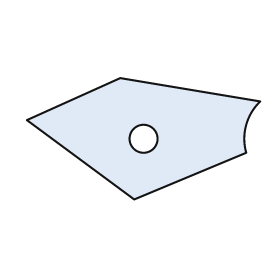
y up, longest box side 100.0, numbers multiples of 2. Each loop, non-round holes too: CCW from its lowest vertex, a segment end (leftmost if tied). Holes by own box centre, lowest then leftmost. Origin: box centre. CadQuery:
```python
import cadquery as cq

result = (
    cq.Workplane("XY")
    .moveTo(-4.0, -26.0)
    .lineTo(44.0, -6.0)
    .threePointArc((44.0, 6.0), (50.0, 16.0))
    .lineTo(-10.0, 26.0)
    .lineTo(-50.0, 8.0)
    .close()
    .moveTo(0.0, 0.0)
    .circle(6.0)
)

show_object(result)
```